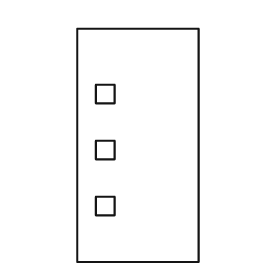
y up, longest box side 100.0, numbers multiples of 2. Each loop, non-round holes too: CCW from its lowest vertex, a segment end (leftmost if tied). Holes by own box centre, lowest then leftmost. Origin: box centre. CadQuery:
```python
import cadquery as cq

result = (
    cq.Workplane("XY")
    .moveTo(-26.0, -50.0)
    .lineTo(26.0, -50.0)
    .lineTo(26.0, 50.0)
    .lineTo(-26.0, 50.0)
    .close()
    .moveTo(-18.0, -30.0)
    .lineTo(-10.0, -30.0)
    .lineTo(-10.0, -22.0)
    .lineTo(-18.0, -22.0)
    .close()
    .moveTo(-18.0, -6.0)
    .lineTo(-10.0, -6.0)
    .lineTo(-10.0, 2.0)
    .lineTo(-18.0, 2.0)
    .close()
    .moveTo(-18.0, 18.0)
    .lineTo(-10.0, 18.0)
    .lineTo(-10.0, 26.0)
    .lineTo(-18.0, 26.0)
    .close()
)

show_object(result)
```